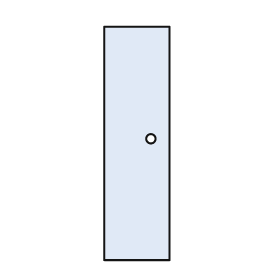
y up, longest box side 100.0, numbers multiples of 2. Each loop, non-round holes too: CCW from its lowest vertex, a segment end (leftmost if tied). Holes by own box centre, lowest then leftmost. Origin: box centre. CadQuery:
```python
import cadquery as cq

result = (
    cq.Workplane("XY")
    .moveTo(-14.0, -50.0)
    .lineTo(14.0, -50.0)
    .lineTo(14.0, 50.0)
    .lineTo(-14.0, 50.0)
    .close()
    .moveTo(6.0, 2.0)
    .circle(2.0)
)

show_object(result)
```